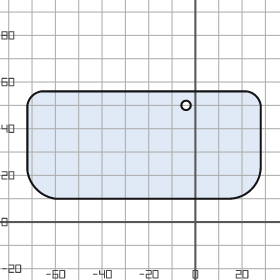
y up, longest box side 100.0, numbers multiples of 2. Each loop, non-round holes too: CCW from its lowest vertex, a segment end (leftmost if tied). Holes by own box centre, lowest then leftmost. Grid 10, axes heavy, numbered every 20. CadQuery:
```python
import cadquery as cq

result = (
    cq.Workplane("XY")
    .moveTo(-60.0, 10.0)
    .lineTo(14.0, 10.0)
    .threePointArc((24.0, 14.0), (28.0, 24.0))
    .lineTo(28.0, 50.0)
    .threePointArc((26.0, 54.0), (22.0, 56.0))
    .lineTo(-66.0, 56.0)
    .threePointArc((-70.0, 54.0), (-72.0, 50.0))
    .lineTo(-72.0, 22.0)
    .threePointArc((-68.0, 14.0), (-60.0, 10.0))
    .close()
    .moveTo(-4.0, 50.0)
    .circle(2.0)
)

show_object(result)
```